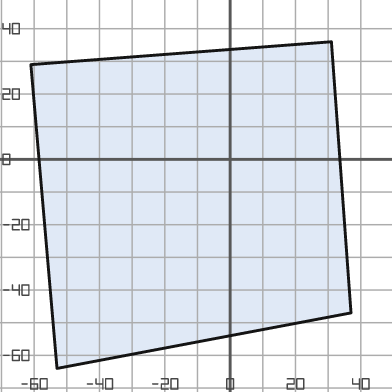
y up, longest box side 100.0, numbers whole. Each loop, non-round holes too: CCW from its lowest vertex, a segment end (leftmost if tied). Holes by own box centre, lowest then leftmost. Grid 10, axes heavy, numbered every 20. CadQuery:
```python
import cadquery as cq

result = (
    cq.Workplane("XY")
    .moveTo(-53.0, -64.0)
    .lineTo(37.0, -47.0)
    .lineTo(31.0, 36.0)
    .lineTo(-61.0, 29.0)
    .close()
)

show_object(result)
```